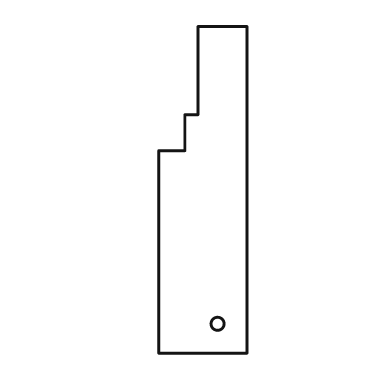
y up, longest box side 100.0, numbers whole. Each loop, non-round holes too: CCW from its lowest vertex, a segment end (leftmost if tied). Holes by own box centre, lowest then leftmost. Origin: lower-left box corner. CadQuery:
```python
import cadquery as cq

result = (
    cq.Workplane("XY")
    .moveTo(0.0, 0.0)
    .lineTo(27.0, 0.0)
    .lineTo(27.0, 100.0)
    .lineTo(12.0, 100.0)
    .lineTo(12.0, 73.0)
    .lineTo(8.0, 73.0)
    .lineTo(8.0, 62.0)
    .lineTo(0.0, 62.0)
    .close()
    .moveTo(18.0, 9.0)
    .circle(2.0)
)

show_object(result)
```